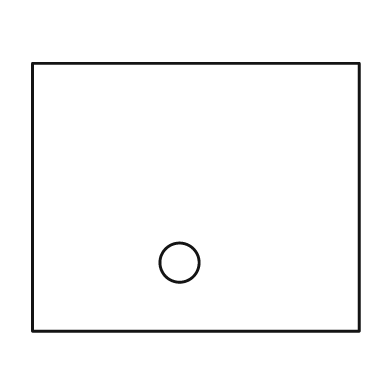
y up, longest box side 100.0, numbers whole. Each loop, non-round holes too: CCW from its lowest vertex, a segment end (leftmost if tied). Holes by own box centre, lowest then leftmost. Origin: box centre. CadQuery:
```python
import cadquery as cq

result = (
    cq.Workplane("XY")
    .moveTo(-50.0, -41.0)
    .lineTo(50.0, -41.0)
    .lineTo(50.0, 41.0)
    .lineTo(-50.0, 41.0)
    .close()
    .moveTo(-5.0, -20.0)
    .circle(6.0)
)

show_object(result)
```